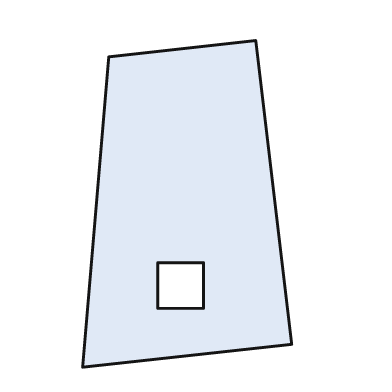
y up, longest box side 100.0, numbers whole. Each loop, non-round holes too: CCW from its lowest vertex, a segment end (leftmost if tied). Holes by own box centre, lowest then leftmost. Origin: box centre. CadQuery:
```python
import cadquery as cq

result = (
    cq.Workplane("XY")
    .moveTo(-32.0, -50.0)
    .lineTo(32.0, -43.0)
    .lineTo(21.0, 50.0)
    .lineTo(-24.0, 45.0)
    .close()
    .moveTo(-9.0, -32.0)
    .lineTo(5.0, -32.0)
    .lineTo(5.0, -18.0)
    .lineTo(-9.0, -18.0)
    .close()
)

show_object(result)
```